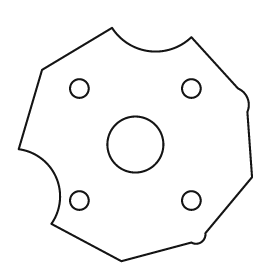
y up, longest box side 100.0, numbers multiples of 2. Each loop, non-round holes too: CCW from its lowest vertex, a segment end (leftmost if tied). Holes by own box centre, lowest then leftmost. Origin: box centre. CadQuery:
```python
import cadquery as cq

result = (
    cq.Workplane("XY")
    .moveTo(-6.0, -50.0)
    .lineTo(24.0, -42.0)
    .threePointArc((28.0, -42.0), (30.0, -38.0))
    .lineTo(50.0, -14.0)
    .lineTo(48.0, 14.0)
    .threePointArc((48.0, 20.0), (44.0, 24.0))
    .lineTo(24.0, 46.0)
    .threePointArc((6.0, 40.0), (-10.0, 50.0))
    .lineTo(-40.0, 32.0)
    .lineTo(-50.0, -2.0)
    .threePointArc((-34.0, -14.0), (-36.0, -34.0))
    .close()
    .moveTo(-24.0, -24.0)
    .circle(4.0)
    .moveTo(24.0, -24.0)
    .circle(4.0)
    .moveTo(0.0, 0.0)
    .circle(12.0)
    .moveTo(-24.0, 24.0)
    .circle(4.0)
    .moveTo(24.0, 24.0)
    .circle(4.0)
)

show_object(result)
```